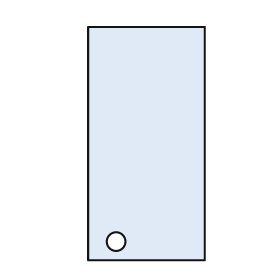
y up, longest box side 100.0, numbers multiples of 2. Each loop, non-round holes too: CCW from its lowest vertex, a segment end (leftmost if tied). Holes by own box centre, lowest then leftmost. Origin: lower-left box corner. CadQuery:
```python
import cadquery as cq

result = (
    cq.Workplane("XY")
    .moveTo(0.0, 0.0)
    .lineTo(50.0, 0.0)
    .lineTo(50.0, 100.0)
    .lineTo(0.0, 100.0)
    .close()
    .moveTo(12.0, 8.0)
    .circle(4.0)
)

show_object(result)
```